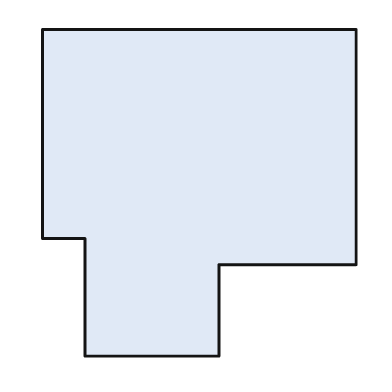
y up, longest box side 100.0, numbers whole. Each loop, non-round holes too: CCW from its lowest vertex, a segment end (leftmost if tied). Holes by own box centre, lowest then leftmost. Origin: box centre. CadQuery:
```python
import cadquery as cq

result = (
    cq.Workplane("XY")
    .moveTo(-35.0, -50.0)
    .lineTo(6.0, -50.0)
    .lineTo(6.0, -22.0)
    .lineTo(48.0, -22.0)
    .lineTo(48.0, 50.0)
    .lineTo(-48.0, 50.0)
    .lineTo(-48.0, -14.0)
    .lineTo(-35.0, -14.0)
    .close()
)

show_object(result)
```